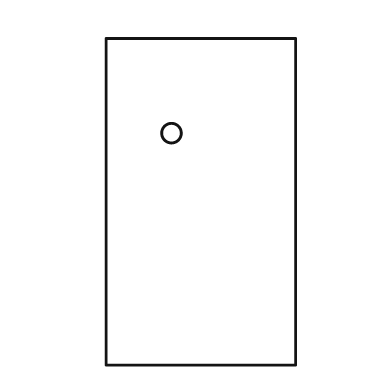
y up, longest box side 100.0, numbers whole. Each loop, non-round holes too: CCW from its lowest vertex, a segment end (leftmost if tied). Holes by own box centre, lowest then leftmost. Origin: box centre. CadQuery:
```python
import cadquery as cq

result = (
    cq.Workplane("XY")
    .moveTo(-29.0, -50.0)
    .lineTo(29.0, -50.0)
    .lineTo(29.0, 50.0)
    .lineTo(-29.0, 50.0)
    .close()
    .moveTo(-9.0, 21.0)
    .circle(3.0)
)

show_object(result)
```